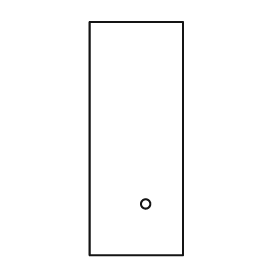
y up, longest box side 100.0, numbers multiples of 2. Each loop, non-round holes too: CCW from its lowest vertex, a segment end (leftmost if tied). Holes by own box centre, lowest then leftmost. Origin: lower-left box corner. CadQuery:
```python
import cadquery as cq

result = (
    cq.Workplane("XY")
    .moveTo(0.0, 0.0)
    .lineTo(40.0, 0.0)
    .lineTo(40.0, 100.0)
    .lineTo(0.0, 100.0)
    .close()
    .moveTo(24.0, 22.0)
    .circle(2.0)
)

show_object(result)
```